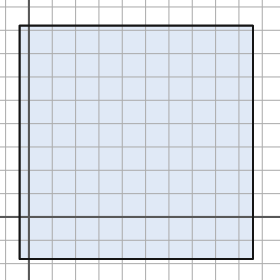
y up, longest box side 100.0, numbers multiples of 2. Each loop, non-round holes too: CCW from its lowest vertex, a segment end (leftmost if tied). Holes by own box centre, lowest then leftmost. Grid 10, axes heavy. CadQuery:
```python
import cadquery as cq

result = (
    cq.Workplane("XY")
    .moveTo(-4.0, -18.0)
    .lineTo(96.0, -18.0)
    .lineTo(96.0, 82.0)
    .lineTo(-4.0, 82.0)
    .close()
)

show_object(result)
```